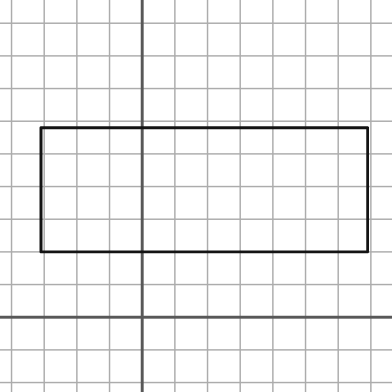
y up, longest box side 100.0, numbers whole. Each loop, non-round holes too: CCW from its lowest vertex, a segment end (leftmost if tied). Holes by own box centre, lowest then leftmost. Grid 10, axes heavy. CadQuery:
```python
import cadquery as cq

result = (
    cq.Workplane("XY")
    .moveTo(-31.0, 20.0)
    .lineTo(69.0, 20.0)
    .lineTo(69.0, 58.0)
    .lineTo(-31.0, 58.0)
    .close()
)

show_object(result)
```